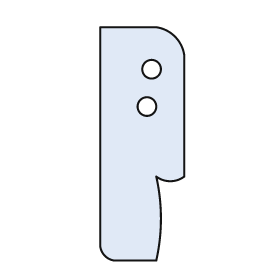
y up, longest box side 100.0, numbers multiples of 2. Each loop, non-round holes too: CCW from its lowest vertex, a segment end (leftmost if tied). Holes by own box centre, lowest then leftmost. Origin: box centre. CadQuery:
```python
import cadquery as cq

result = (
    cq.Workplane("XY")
    .moveTo(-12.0, -50.0)
    .lineTo(6.0, -50.0)
    .threePointArc((8.0, -32.0), (6.0, -14.0))
    .threePointArc((12.0, -16.0), (18.0, -14.0))
    .lineTo(18.0, 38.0)
    .threePointArc((14.0, 46.0), (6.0, 50.0))
    .lineTo(-18.0, 50.0)
    .lineTo(-18.0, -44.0)
    .threePointArc((-16.0, -48.0), (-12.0, -50.0))
    .close()
    .moveTo(2.0, 16.0)
    .circle(4.0)
    .moveTo(4.0, 32.0)
    .circle(4.0)
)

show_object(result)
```